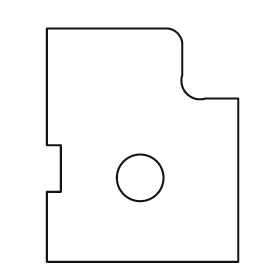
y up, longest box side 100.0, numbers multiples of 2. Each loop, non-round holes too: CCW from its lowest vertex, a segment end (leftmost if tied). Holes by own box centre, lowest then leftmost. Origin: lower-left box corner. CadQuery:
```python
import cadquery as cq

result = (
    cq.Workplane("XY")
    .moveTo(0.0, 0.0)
    .lineTo(82.0, 0.0)
    .lineTo(82.0, 70.0)
    .lineTo(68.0, 70.0)
    .threePointArc((60.0, 72.0), (58.0, 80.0))
    .lineTo(58.0, 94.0)
    .threePointArc((56.0, 98.0), (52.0, 100.0))
    .lineTo(0.0, 100.0)
    .lineTo(0.0, 50.0)
    .lineTo(6.0, 50.0)
    .lineTo(6.0, 30.0)
    .lineTo(0.0, 30.0)
    .close()
    .moveTo(40.0, 36.0)
    .circle(10.0)
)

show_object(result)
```